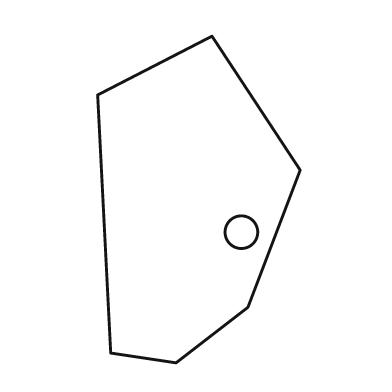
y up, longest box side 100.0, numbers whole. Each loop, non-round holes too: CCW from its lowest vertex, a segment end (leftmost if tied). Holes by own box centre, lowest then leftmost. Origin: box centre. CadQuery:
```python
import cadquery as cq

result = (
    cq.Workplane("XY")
    .moveTo(-7.0, -50.0)
    .lineTo(15.0, -33.0)
    .lineTo(31.0, 9.0)
    .lineTo(4.0, 50.0)
    .lineTo(-31.0, 32.0)
    .lineTo(-27.0, -47.0)
    .close()
    .moveTo(13.0, -10.0)
    .circle(5.0)
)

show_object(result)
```